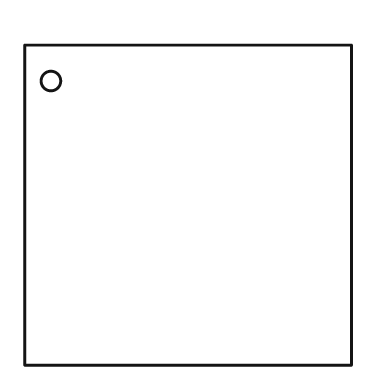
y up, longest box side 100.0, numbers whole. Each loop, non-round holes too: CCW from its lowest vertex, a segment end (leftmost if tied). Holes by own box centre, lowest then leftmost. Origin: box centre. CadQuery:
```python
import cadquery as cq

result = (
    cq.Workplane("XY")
    .moveTo(-50.0, -49.0)
    .lineTo(50.0, -49.0)
    .lineTo(50.0, 49.0)
    .lineTo(-50.0, 49.0)
    .close()
    .moveTo(-42.0, 38.0)
    .circle(3.0)
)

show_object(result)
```